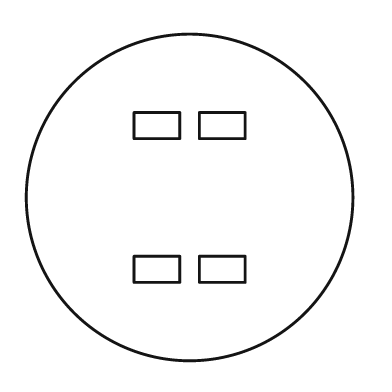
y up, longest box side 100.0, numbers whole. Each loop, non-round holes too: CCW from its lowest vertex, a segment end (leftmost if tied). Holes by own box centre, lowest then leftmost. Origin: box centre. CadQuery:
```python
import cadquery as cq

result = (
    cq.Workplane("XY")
    .moveTo(0.0, 0.0)
    .circle(50.0)
    .moveTo(-17.0, -26.0)
    .lineTo(-3.0, -26.0)
    .lineTo(-3.0, -18.0)
    .lineTo(-17.0, -18.0)
    .close()
    .moveTo(3.0, -26.0)
    .lineTo(17.0, -26.0)
    .lineTo(17.0, -18.0)
    .lineTo(3.0, -18.0)
    .close()
    .moveTo(-17.0, 18.0)
    .lineTo(-3.0, 18.0)
    .lineTo(-3.0, 26.0)
    .lineTo(-17.0, 26.0)
    .close()
    .moveTo(3.0, 18.0)
    .lineTo(17.0, 18.0)
    .lineTo(17.0, 26.0)
    .lineTo(3.0, 26.0)
    .close()
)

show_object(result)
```